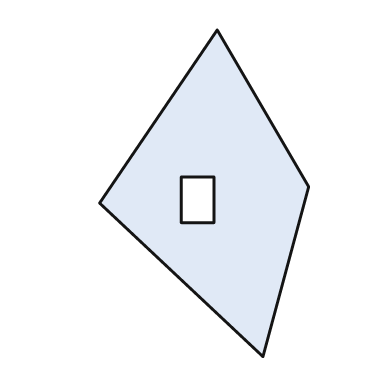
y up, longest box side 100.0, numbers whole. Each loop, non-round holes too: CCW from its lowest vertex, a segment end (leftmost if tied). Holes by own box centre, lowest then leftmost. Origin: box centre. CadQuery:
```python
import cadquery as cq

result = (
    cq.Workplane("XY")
    .moveTo(18.0, -50.0)
    .lineTo(32.0, 2.0)
    .lineTo(4.0, 50.0)
    .lineTo(-32.0, -3.0)
    .close()
    .moveTo(-7.0, -9.0)
    .lineTo(3.0, -9.0)
    .lineTo(3.0, 5.0)
    .lineTo(-7.0, 5.0)
    .close()
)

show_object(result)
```